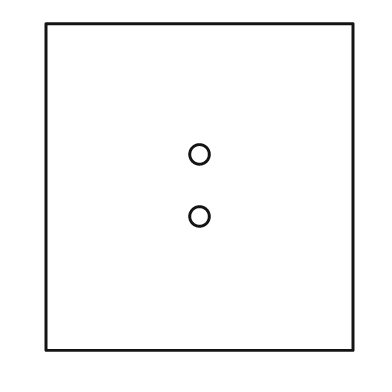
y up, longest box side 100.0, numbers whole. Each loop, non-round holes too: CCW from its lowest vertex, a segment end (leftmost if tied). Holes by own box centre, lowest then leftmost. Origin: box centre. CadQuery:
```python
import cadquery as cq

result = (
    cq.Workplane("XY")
    .moveTo(-47.0, -50.0)
    .lineTo(47.0, -50.0)
    .lineTo(47.0, 50.0)
    .lineTo(-47.0, 50.0)
    .close()
    .moveTo(0.0, -9.0)
    .circle(3.0)
    .moveTo(0.0, 10.0)
    .circle(3.0)
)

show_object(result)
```